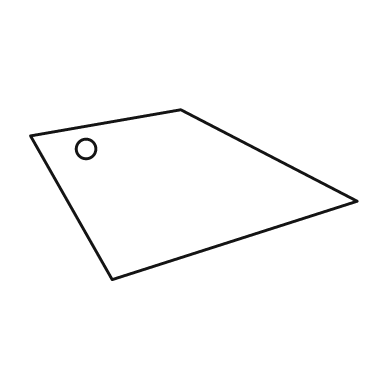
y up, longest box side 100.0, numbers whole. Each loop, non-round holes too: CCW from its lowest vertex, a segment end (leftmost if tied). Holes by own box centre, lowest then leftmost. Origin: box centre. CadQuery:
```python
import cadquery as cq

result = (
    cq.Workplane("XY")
    .moveTo(-25.0, -26.0)
    .lineTo(50.0, -2.0)
    .lineTo(-4.0, 26.0)
    .lineTo(-50.0, 18.0)
    .close()
    .moveTo(-33.0, 14.0)
    .circle(3.0)
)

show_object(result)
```